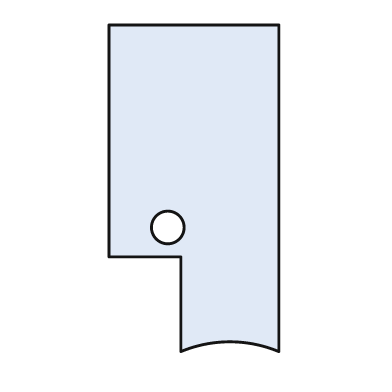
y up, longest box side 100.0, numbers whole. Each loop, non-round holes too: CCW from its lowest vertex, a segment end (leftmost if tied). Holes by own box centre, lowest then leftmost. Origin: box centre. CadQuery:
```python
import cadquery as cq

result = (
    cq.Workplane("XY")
    .moveTo(-4.0, -50.0)
    .threePointArc((11.0, -47.0), (26.0, -50.0))
    .lineTo(26.0, 50.0)
    .lineTo(-26.0, 50.0)
    .lineTo(-26.0, -21.0)
    .lineTo(-4.0, -21.0)
    .close()
    .moveTo(-8.0, -12.0)
    .circle(5.0)
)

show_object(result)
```